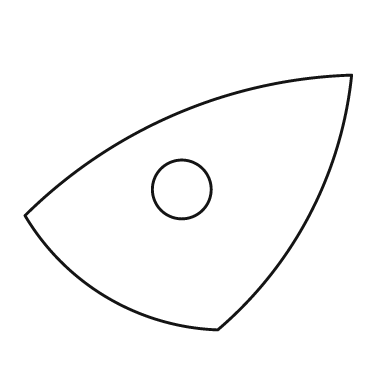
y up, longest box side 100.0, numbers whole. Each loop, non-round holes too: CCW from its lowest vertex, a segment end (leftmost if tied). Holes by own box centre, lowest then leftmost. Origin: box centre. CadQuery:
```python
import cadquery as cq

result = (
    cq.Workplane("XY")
    .moveTo(9.0, -39.0)
    .threePointArc((37.0, -4.0), (50.0, 39.0))
    .threePointArc((-4.0, 27.0), (-50.0, -4.0))
    .threePointArc((-25.0, -29.0), (9.0, -39.0))
    .close()
    .moveTo(-2.0, 4.0)
    .circle(9.0)
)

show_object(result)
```